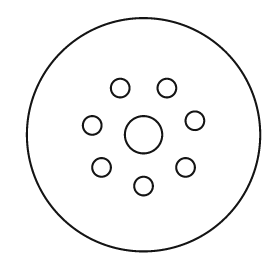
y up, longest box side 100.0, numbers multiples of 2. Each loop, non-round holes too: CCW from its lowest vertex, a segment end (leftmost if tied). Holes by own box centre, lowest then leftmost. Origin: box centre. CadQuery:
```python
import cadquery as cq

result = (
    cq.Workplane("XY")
    .moveTo(0.0, 0.0)
    .circle(50.0)
    .moveTo(0.0, -22.0)
    .circle(4.0)
    .moveTo(-18.0, -14.0)
    .circle(4.0)
    .moveTo(18.0, -14.0)
    .circle(4.0)
    .moveTo(0.0, 0.0)
    .circle(8.0)
    .moveTo(-22.0, 4.0)
    .circle(4.0)
    .moveTo(22.0, 6.0)
    .circle(4.0)
    .moveTo(-10.0, 20.0)
    .circle(4.0)
    .moveTo(10.0, 20.0)
    .circle(4.0)
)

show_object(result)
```